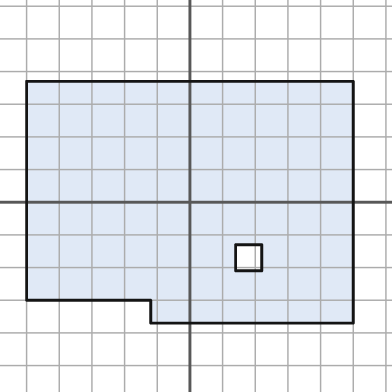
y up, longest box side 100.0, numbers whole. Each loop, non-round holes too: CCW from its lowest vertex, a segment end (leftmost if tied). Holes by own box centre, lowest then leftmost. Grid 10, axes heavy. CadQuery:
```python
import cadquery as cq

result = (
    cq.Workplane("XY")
    .moveTo(-12.0, -37.0)
    .lineTo(50.0, -37.0)
    .lineTo(50.0, 37.0)
    .lineTo(-50.0, 37.0)
    .lineTo(-50.0, -30.0)
    .lineTo(-12.0, -30.0)
    .close()
    .moveTo(14.0, -21.0)
    .lineTo(22.0, -21.0)
    .lineTo(22.0, -13.0)
    .lineTo(14.0, -13.0)
    .close()
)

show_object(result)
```